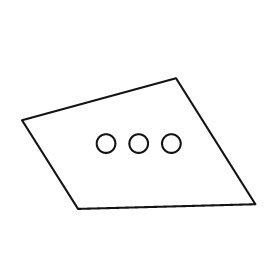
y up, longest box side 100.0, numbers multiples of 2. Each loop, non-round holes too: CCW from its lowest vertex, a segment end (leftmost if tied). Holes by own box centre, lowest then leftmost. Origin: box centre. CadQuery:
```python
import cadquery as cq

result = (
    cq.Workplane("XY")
    .moveTo(-26.0, -28.0)
    .lineTo(50.0, -26.0)
    .lineTo(16.0, 28.0)
    .lineTo(-50.0, 10.0)
    .close()
    .moveTo(-14.0, 0.0)
    .circle(4.0)
    .moveTo(0.0, 0.0)
    .circle(4.0)
    .moveTo(14.0, 0.0)
    .circle(4.0)
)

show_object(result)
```